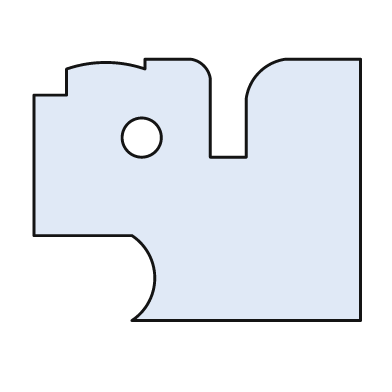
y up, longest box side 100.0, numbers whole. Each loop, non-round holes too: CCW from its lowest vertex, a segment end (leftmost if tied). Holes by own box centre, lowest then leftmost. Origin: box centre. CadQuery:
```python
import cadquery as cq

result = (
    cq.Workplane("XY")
    .moveTo(-20.0, -40.0)
    .lineTo(50.0, -40.0)
    .lineTo(50.0, 40.0)
    .lineTo(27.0, 40.0)
    .threePointArc((19.0, 36.0), (15.0, 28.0))
    .lineTo(15.0, 10.0)
    .lineTo(4.0, 10.0)
    .lineTo(4.0, 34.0)
    .threePointArc((2.0, 38.0), (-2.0, 40.0))
    .lineTo(-16.0, 40.0)
    .lineTo(-16.0, 37.0)
    .threePointArc((-28.0, 39.0), (-40.0, 37.0))
    .lineTo(-40.0, 29.0)
    .lineTo(-50.0, 29.0)
    .lineTo(-50.0, -14.0)
    .lineTo(-20.0, -14.0)
    .threePointArc((-13.0, -27.0), (-20.0, -40.0))
    .close()
    .moveTo(-17.0, 16.0)
    .circle(6.0)
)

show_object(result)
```